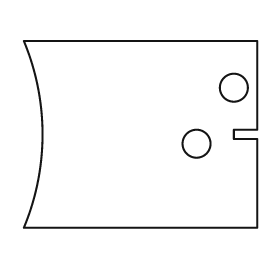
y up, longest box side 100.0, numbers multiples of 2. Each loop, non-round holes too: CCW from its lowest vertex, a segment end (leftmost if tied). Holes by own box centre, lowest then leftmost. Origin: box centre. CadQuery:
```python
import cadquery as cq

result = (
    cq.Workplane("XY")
    .moveTo(-50.0, -40.0)
    .lineTo(50.0, -40.0)
    .lineTo(50.0, -2.0)
    .lineTo(40.0, -2.0)
    .lineTo(40.0, 2.0)
    .lineTo(50.0, 2.0)
    .lineTo(50.0, 40.0)
    .lineTo(-50.0, 40.0)
    .threePointArc((-42.0, 0.0), (-50.0, -40.0))
    .close()
    .moveTo(24.0, -4.0)
    .circle(6.0)
    .moveTo(40.0, 20.0)
    .circle(6.0)
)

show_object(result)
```